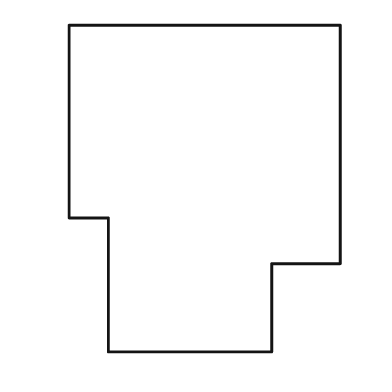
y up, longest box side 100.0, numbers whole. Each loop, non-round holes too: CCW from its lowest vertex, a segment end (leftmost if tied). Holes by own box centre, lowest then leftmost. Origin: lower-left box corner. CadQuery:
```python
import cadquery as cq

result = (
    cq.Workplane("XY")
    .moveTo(12.0, 0.0)
    .lineTo(62.0, 0.0)
    .lineTo(62.0, 27.0)
    .lineTo(83.0, 27.0)
    .lineTo(83.0, 100.0)
    .lineTo(0.0, 100.0)
    .lineTo(0.0, 41.0)
    .lineTo(12.0, 41.0)
    .close()
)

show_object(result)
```